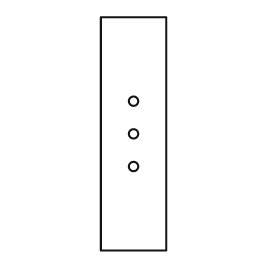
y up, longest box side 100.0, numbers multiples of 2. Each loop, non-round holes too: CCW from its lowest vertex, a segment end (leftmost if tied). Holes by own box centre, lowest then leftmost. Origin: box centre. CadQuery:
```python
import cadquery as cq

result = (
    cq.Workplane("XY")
    .moveTo(-14.0, -50.0)
    .lineTo(14.0, -50.0)
    .lineTo(14.0, 50.0)
    .lineTo(-14.0, 50.0)
    .close()
    .moveTo(0.0, -14.0)
    .circle(2.0)
    .moveTo(0.0, 0.0)
    .circle(2.0)
    .moveTo(0.0, 14.0)
    .circle(2.0)
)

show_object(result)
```